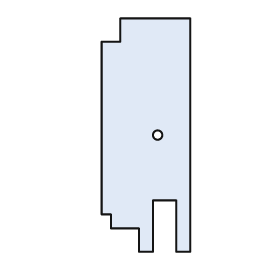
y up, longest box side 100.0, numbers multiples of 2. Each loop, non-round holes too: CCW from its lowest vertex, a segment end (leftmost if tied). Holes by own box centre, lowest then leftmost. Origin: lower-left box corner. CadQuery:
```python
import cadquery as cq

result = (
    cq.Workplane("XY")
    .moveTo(16.0, 0.0)
    .lineTo(22.0, 0.0)
    .lineTo(22.0, 22.0)
    .lineTo(32.0, 22.0)
    .lineTo(32.0, 0.0)
    .lineTo(38.0, 0.0)
    .lineTo(38.0, 100.0)
    .lineTo(8.0, 100.0)
    .lineTo(8.0, 90.0)
    .lineTo(0.0, 90.0)
    .lineTo(0.0, 16.0)
    .lineTo(4.0, 16.0)
    .lineTo(4.0, 10.0)
    .lineTo(16.0, 10.0)
    .close()
    .moveTo(24.0, 50.0)
    .circle(2.0)
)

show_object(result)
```